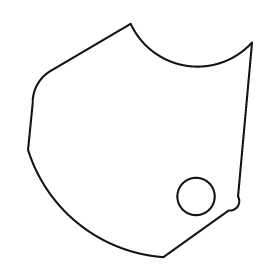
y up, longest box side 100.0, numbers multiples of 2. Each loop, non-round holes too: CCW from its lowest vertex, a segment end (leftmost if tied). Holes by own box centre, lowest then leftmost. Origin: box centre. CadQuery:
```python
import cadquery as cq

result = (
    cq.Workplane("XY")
    .moveTo(10.0, -50.0)
    .lineTo(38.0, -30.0)
    .threePointArc((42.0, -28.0), (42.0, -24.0))
    .lineTo(48.0, 42.0)
    .threePointArc((20.0, 32.0), (-4.0, 50.0))
    .lineTo(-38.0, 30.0)
    .threePointArc((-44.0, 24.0), (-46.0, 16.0))
    .lineTo(-48.0, -4.0)
    .threePointArc((-26.0, -36.0), (10.0, -50.0))
    .close()
    .moveTo(24.0, -24.0)
    .circle(8.0)
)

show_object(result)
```